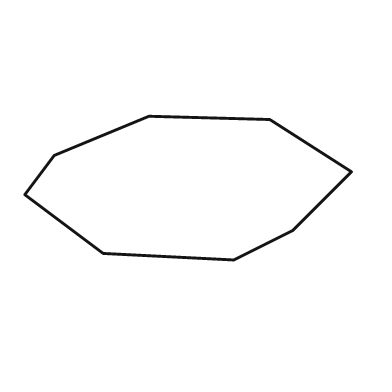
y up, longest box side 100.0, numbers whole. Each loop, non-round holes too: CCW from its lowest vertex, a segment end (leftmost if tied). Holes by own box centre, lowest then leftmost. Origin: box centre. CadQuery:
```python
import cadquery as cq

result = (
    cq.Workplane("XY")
    .moveTo(14.0, -22.0)
    .lineTo(32.0, -13.0)
    .lineTo(50.0, 5.0)
    .lineTo(25.0, 21.0)
    .lineTo(-12.0, 22.0)
    .lineTo(-41.0, 10.0)
    .lineTo(-50.0, -2.0)
    .lineTo(-26.0, -20.0)
    .close()
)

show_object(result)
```